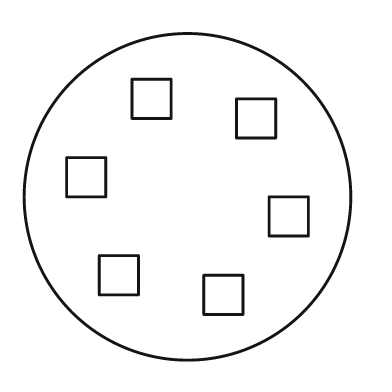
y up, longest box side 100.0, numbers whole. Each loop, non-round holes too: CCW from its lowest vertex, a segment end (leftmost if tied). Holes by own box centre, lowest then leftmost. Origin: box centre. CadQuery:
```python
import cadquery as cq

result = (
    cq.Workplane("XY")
    .moveTo(0.0, 0.0)
    .circle(50.0)
    .moveTo(5.0, -36.0)
    .lineTo(17.0, -36.0)
    .lineTo(17.0, -24.0)
    .lineTo(5.0, -24.0)
    .close()
    .moveTo(-27.0, -30.0)
    .lineTo(-15.0, -30.0)
    .lineTo(-15.0, -18.0)
    .lineTo(-27.0, -18.0)
    .close()
    .moveTo(25.0, -12.0)
    .lineTo(37.0, -12.0)
    .lineTo(37.0, 0.0)
    .lineTo(25.0, 0.0)
    .close()
    .moveTo(-37.0, 0.0)
    .lineTo(-25.0, 0.0)
    .lineTo(-25.0, 12.0)
    .lineTo(-37.0, 12.0)
    .close()
    .moveTo(15.0, 18.0)
    .lineTo(27.0, 18.0)
    .lineTo(27.0, 30.0)
    .lineTo(15.0, 30.0)
    .close()
    .moveTo(-17.0, 24.0)
    .lineTo(-5.0, 24.0)
    .lineTo(-5.0, 36.0)
    .lineTo(-17.0, 36.0)
    .close()
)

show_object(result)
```